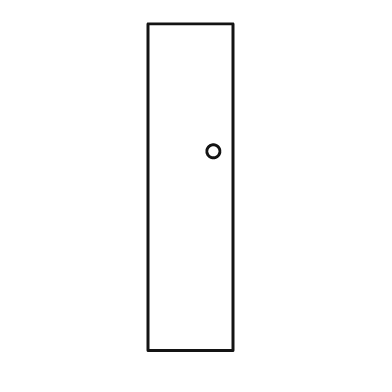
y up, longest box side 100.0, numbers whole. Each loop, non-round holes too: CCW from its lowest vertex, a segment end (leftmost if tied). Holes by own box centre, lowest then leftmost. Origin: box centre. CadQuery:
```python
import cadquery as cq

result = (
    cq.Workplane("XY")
    .moveTo(-13.0, -50.0)
    .lineTo(13.0, -50.0)
    .lineTo(13.0, 50.0)
    .lineTo(-13.0, 50.0)
    .close()
    .moveTo(7.0, 11.0)
    .circle(2.0)
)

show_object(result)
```